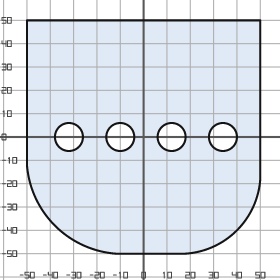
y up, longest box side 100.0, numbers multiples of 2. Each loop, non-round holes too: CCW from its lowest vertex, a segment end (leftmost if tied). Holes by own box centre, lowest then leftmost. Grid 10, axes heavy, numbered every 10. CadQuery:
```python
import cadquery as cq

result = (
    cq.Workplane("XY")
    .moveTo(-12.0, -50.0)
    .lineTo(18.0, -50.0)
    .threePointArc((40.0, -40.0), (50.0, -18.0))
    .lineTo(50.0, 50.0)
    .lineTo(-50.0, 50.0)
    .lineTo(-50.0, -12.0)
    .threePointArc((-38.0, -38.0), (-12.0, -50.0))
    .close()
    .moveTo(-32.0, 0.0)
    .circle(6.0)
    .moveTo(-10.0, 0.0)
    .circle(6.0)
    .moveTo(12.0, 0.0)
    .circle(6.0)
    .moveTo(34.0, 0.0)
    .circle(6.0)
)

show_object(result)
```